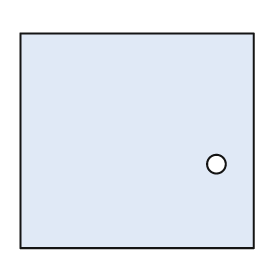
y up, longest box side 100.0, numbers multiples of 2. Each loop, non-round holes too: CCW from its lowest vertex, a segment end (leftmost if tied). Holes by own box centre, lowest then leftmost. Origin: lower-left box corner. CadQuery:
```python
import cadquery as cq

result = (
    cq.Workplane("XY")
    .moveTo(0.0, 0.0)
    .lineTo(100.0, 0.0)
    .lineTo(100.0, 92.0)
    .lineTo(0.0, 92.0)
    .close()
    .moveTo(84.0, 36.0)
    .circle(4.0)
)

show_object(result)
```